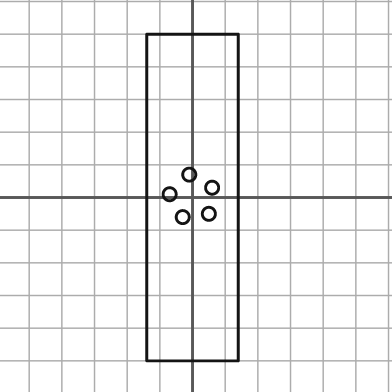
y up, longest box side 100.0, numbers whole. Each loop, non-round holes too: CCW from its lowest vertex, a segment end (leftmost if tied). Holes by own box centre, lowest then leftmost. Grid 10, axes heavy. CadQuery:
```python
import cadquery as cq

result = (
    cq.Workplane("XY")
    .moveTo(-14.0, -50.0)
    .lineTo(14.0, -50.0)
    .lineTo(14.0, 50.0)
    .lineTo(-14.0, 50.0)
    .close()
    .moveTo(-3.0, -6.0)
    .circle(2.0)
    .moveTo(5.0, -5.0)
    .circle(2.0)
    .moveTo(-7.0, 1.0)
    .circle(2.0)
    .moveTo(6.0, 3.0)
    .circle(2.0)
    .moveTo(-1.0, 7.0)
    .circle(2.0)
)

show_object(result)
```